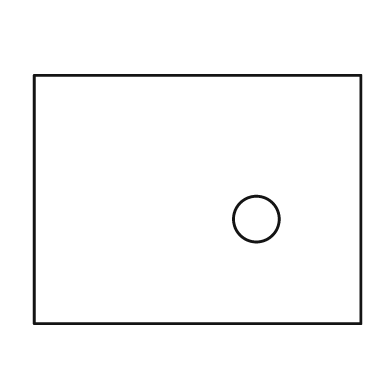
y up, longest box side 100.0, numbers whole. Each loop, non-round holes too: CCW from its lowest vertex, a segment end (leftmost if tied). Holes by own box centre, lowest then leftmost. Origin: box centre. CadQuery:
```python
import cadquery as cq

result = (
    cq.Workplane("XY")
    .moveTo(-50.0, -38.0)
    .lineTo(50.0, -38.0)
    .lineTo(50.0, 38.0)
    .lineTo(-50.0, 38.0)
    .close()
    .moveTo(18.0, -6.0)
    .circle(7.0)
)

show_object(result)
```